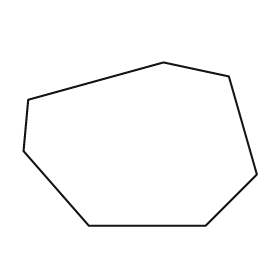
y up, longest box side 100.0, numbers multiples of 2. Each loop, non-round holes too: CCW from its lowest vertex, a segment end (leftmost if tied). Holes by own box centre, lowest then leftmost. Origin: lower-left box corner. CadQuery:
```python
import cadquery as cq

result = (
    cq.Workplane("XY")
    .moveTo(28.0, 0.0)
    .lineTo(78.0, 0.0)
    .lineTo(100.0, 22.0)
    .lineTo(88.0, 64.0)
    .lineTo(60.0, 70.0)
    .lineTo(2.0, 54.0)
    .lineTo(0.0, 32.0)
    .close()
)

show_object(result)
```